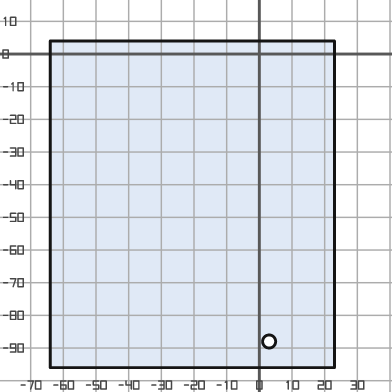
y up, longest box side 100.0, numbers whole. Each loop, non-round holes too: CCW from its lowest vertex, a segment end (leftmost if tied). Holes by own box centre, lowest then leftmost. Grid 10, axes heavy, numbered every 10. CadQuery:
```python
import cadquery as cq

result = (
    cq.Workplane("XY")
    .moveTo(-64.0, -96.0)
    .lineTo(23.0, -96.0)
    .lineTo(23.0, 4.0)
    .lineTo(-64.0, 4.0)
    .close()
    .moveTo(3.0, -88.0)
    .circle(2.0)
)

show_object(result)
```